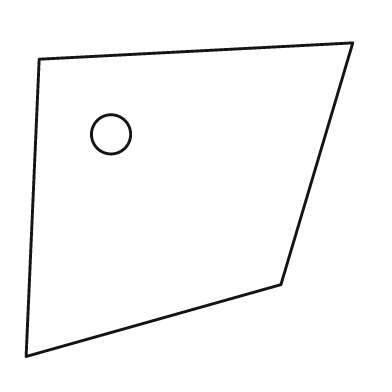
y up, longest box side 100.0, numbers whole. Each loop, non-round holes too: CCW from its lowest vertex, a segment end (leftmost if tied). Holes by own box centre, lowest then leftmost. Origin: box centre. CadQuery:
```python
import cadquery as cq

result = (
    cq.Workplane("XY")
    .moveTo(-50.0, -48.0)
    .lineTo(28.0, -26.0)
    .lineTo(50.0, 48.0)
    .lineTo(-46.0, 43.0)
    .close()
    .moveTo(-24.0, 20.0)
    .circle(6.0)
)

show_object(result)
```